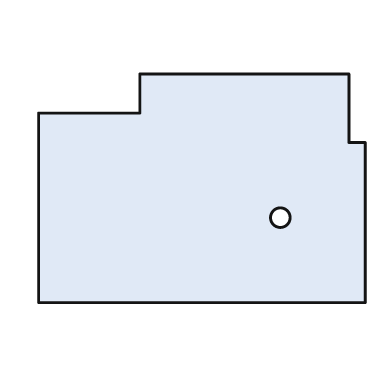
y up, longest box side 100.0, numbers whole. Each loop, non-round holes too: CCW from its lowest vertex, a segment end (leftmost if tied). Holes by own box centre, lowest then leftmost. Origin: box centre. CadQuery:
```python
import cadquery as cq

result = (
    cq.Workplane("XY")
    .moveTo(-50.0, -35.0)
    .lineTo(50.0, -35.0)
    .lineTo(50.0, 14.0)
    .lineTo(45.0, 14.0)
    .lineTo(45.0, 35.0)
    .lineTo(-19.0, 35.0)
    .lineTo(-19.0, 23.0)
    .lineTo(-50.0, 23.0)
    .close()
    .moveTo(24.0, -9.0)
    .circle(3.0)
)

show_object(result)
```